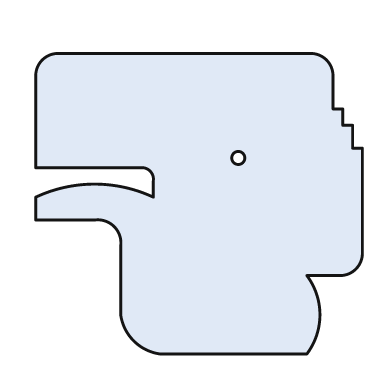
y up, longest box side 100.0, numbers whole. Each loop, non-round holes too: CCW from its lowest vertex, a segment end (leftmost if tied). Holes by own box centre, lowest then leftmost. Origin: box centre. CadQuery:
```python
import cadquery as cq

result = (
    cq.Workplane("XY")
    .moveTo(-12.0, -46.0)
    .lineTo(33.0, -46.0)
    .threePointArc((37.0, -34.0), (33.0, -22.0))
    .lineTo(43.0, -22.0)
    .threePointArc((48.0, -20.0), (50.0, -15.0))
    .lineTo(50.0, 17.0)
    .lineTo(47.0, 17.0)
    .lineTo(47.0, 24.0)
    .lineTo(44.0, 24.0)
    .lineTo(44.0, 29.0)
    .lineTo(41.0, 29.0)
    .lineTo(41.0, 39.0)
    .threePointArc((39.0, 44.0), (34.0, 46.0))
    .lineTo(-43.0, 46.0)
    .threePointArc((-48.0, 44.0), (-50.0, 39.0))
    .lineTo(-50.0, 11.0)
    .lineTo(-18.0, 11.0)
    .threePointArc((-15.0, 10.0), (-14.0, 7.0))
    .lineTo(-14.0, 2.0)
    .threePointArc((-32.0, 6.0), (-50.0, 2.0))
    .lineTo(-50.0, -5.0)
    .lineTo(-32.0, -5.0)
    .threePointArc((-26.0, -7.0), (-24.0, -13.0))
    .lineTo(-24.0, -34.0)
    .threePointArc((-20.0, -42.0), (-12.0, -46.0))
    .close()
    .moveTo(12.0, 14.0)
    .circle(2.0)
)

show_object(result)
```